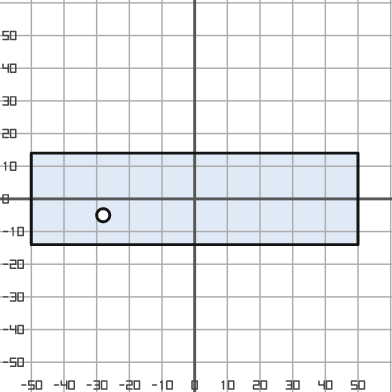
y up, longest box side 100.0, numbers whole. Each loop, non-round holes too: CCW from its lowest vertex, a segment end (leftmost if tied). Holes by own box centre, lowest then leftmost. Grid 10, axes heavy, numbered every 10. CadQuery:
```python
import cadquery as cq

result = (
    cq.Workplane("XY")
    .moveTo(-50.0, -14.0)
    .lineTo(50.0, -14.0)
    .lineTo(50.0, 14.0)
    .lineTo(-50.0, 14.0)
    .close()
    .moveTo(-28.0, -5.0)
    .circle(2.0)
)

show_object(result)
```